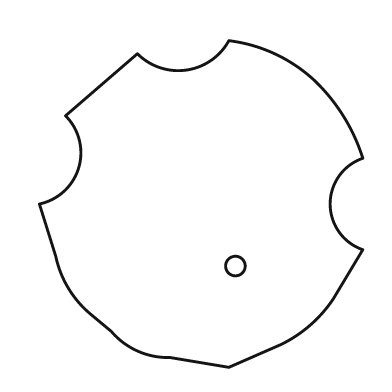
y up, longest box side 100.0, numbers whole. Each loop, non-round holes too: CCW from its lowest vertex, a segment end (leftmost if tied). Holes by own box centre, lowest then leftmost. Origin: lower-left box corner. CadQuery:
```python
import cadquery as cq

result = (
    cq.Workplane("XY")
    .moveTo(58.0, 0.0)
    .lineTo(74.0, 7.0)
    .threePointArc((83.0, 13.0), (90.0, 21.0))
    .lineTo(99.0, 36.0)
    .threePointArc((89.0, 50.0), (99.0, 64.0))
    .threePointArc((93.0, 77.0), (84.0, 88.0))
    .threePointArc((72.0, 96.0), (58.0, 100.0))
    .threePointArc((45.0, 91.0), (30.0, 96.0))
    .lineTo(8.0, 77.0)
    .threePointArc((12.0, 61.0), (0.0, 50.0))
    .lineTo(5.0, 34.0)
    .threePointArc((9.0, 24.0), (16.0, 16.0))
    .lineTo(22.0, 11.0)
    .threePointArc((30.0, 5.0), (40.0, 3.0))
    .close()
    .moveTo(60.0, 31.0)
    .circle(3.0)
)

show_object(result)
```